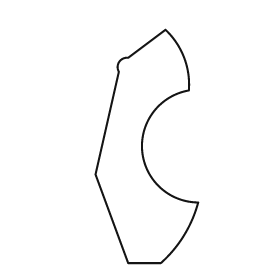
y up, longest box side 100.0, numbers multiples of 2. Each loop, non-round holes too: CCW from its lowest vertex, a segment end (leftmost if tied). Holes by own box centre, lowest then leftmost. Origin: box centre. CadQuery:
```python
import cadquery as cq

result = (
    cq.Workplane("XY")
    .moveTo(-8.0, -50.0)
    .lineTo(6.0, -50.0)
    .threePointArc((16.0, -38.0), (22.0, -24.0))
    .threePointArc((-2.0, -2.0), (18.0, 24.0))
    .threePointArc((16.0, 38.0), (8.0, 50.0))
    .lineTo(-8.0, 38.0)
    .threePointArc((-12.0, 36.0), (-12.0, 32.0))
    .lineTo(-22.0, -12.0)
    .close()
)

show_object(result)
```